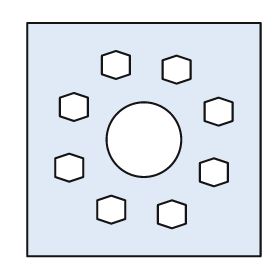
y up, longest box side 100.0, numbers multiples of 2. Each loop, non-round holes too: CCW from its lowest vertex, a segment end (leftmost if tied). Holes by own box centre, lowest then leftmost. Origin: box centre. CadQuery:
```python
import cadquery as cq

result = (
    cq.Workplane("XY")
    .moveTo(-50.0, -50.0)
    .lineTo(50.0, -50.0)
    .lineTo(50.0, 50.0)
    .lineTo(-50.0, 50.0)
    .close()
    .moveTo(12.0, -38.0)
    .lineTo(18.0, -36.0)
    .lineTo(18.0, -28.0)
    .lineTo(12.0, -26.0)
    .lineTo(6.0, -28.0)
    .lineTo(6.0, -36.0)
    .close()
    .moveTo(-14.0, -36.0)
    .lineTo(-8.0, -34.0)
    .lineTo(-8.0, -26.0)
    .lineTo(-14.0, -24.0)
    .lineTo(-20.0, -26.0)
    .lineTo(-20.0, -34.0)
    .close()
    .moveTo(30.0, -20.0)
    .lineTo(36.0, -18.0)
    .lineTo(36.0, -10.0)
    .lineTo(30.0, -8.0)
    .lineTo(24.0, -10.0)
    .lineTo(24.0, -18.0)
    .close()
    .moveTo(-32.0, -18.0)
    .lineTo(-26.0, -16.0)
    .lineTo(-26.0, -8.0)
    .lineTo(-32.0, -6.0)
    .lineTo(-38.0, -8.0)
    .lineTo(-38.0, -16.0)
    .close()
    .moveTo(0.0, 0.0)
    .circle(16.0)
    .moveTo(32.0, 6.0)
    .lineTo(38.0, 8.0)
    .lineTo(38.0, 16.0)
    .lineTo(32.0, 18.0)
    .lineTo(26.0, 16.0)
    .lineTo(26.0, 8.0)
    .close()
    .moveTo(-30.0, 8.0)
    .lineTo(-24.0, 10.0)
    .lineTo(-24.0, 18.0)
    .lineTo(-30.0, 20.0)
    .lineTo(-36.0, 18.0)
    .lineTo(-36.0, 10.0)
    .close()
    .moveTo(14.0, 24.0)
    .lineTo(20.0, 26.0)
    .lineTo(20.0, 34.0)
    .lineTo(14.0, 36.0)
    .lineTo(8.0, 34.0)
    .lineTo(8.0, 26.0)
    .close()
    .moveTo(-12.0, 26.0)
    .lineTo(-6.0, 28.0)
    .lineTo(-6.0, 36.0)
    .lineTo(-12.0, 38.0)
    .lineTo(-18.0, 36.0)
    .lineTo(-18.0, 28.0)
    .close()
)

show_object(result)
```